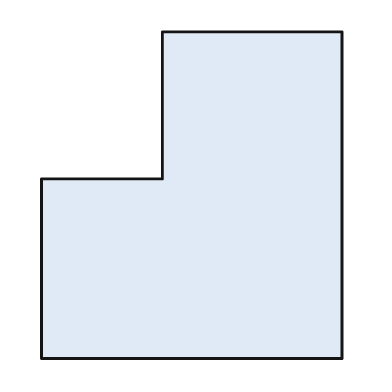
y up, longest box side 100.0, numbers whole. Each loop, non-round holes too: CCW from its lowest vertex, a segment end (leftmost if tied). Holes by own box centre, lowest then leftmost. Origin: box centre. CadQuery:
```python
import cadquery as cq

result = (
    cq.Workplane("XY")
    .moveTo(-46.0, -50.0)
    .lineTo(46.0, -50.0)
    .lineTo(46.0, 50.0)
    .lineTo(-9.0, 50.0)
    .lineTo(-9.0, 5.0)
    .lineTo(-46.0, 5.0)
    .close()
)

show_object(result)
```